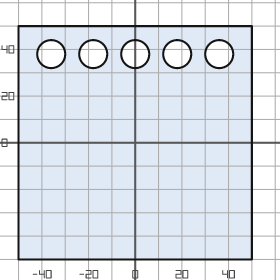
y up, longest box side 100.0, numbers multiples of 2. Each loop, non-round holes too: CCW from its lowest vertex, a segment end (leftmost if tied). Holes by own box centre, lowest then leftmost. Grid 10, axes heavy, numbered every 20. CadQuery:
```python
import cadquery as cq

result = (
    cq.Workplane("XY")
    .moveTo(-50.0, -50.0)
    .lineTo(50.0, -50.0)
    .lineTo(50.0, 50.0)
    .lineTo(-50.0, 50.0)
    .close()
    .moveTo(-36.0, 38.0)
    .circle(6.0)
    .moveTo(-18.0, 38.0)
    .circle(6.0)
    .moveTo(0.0, 38.0)
    .circle(6.0)
    .moveTo(18.0, 38.0)
    .circle(6.0)
    .moveTo(36.0, 38.0)
    .circle(6.0)
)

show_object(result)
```